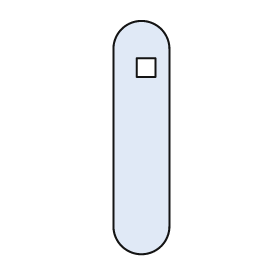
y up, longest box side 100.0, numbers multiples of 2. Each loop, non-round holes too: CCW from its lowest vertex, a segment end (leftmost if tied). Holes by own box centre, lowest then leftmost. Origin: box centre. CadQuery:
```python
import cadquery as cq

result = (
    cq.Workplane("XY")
    .moveTo(-12.0, -38.0)
    .threePointArc((0.0, -50.0), (12.0, -38.0))
    .lineTo(12.0, 38.0)
    .threePointArc((0.0, 50.0), (-12.0, 38.0))
    .close()
    .moveTo(-2.0, 26.0)
    .lineTo(6.0, 26.0)
    .lineTo(6.0, 34.0)
    .lineTo(-2.0, 34.0)
    .close()
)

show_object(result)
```